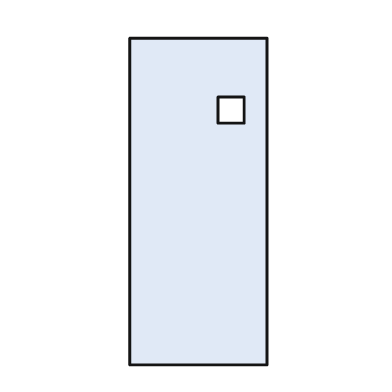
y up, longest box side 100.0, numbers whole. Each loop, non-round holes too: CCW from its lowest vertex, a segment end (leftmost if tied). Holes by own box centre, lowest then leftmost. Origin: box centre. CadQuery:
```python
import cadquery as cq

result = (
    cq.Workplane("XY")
    .moveTo(-21.0, -50.0)
    .lineTo(21.0, -50.0)
    .lineTo(21.0, 50.0)
    .lineTo(-21.0, 50.0)
    .close()
    .moveTo(6.0, 24.0)
    .lineTo(14.0, 24.0)
    .lineTo(14.0, 32.0)
    .lineTo(6.0, 32.0)
    .close()
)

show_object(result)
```